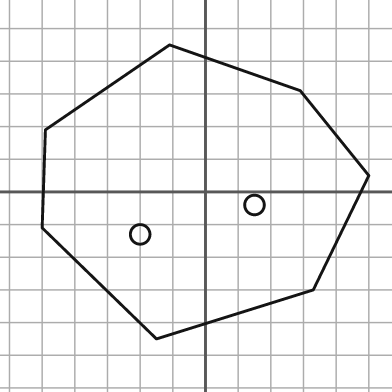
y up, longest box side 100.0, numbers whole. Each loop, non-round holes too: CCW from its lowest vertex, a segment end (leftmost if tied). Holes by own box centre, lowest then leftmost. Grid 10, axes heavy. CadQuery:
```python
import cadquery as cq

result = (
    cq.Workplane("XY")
    .moveTo(-15.0, -45.0)
    .lineTo(33.0, -30.0)
    .lineTo(50.0, 5.0)
    .lineTo(29.0, 31.0)
    .lineTo(-11.0, 45.0)
    .lineTo(-49.0, 19.0)
    .lineTo(-50.0, -11.0)
    .close()
    .moveTo(-20.0, -13.0)
    .circle(3.0)
    .moveTo(15.0, -4.0)
    .circle(3.0)
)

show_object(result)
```